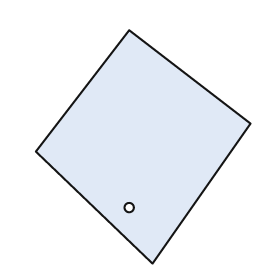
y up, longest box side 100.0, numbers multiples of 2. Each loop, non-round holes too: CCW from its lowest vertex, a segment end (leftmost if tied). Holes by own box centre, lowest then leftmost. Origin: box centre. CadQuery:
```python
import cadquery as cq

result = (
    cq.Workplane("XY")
    .moveTo(4.0, -50.0)
    .lineTo(46.0, 10.0)
    .lineTo(-6.0, 50.0)
    .lineTo(-46.0, -2.0)
    .close()
    .moveTo(-6.0, -26.0)
    .circle(2.0)
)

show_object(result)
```